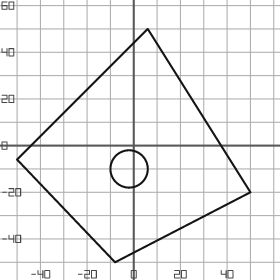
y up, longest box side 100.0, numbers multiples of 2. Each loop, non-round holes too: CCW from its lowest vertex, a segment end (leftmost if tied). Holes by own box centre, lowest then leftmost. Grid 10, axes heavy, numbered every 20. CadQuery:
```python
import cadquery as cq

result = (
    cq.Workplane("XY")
    .moveTo(-8.0, -50.0)
    .lineTo(50.0, -20.0)
    .lineTo(6.0, 50.0)
    .lineTo(-50.0, -6.0)
    .close()
    .moveTo(-2.0, -10.0)
    .circle(8.0)
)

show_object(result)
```